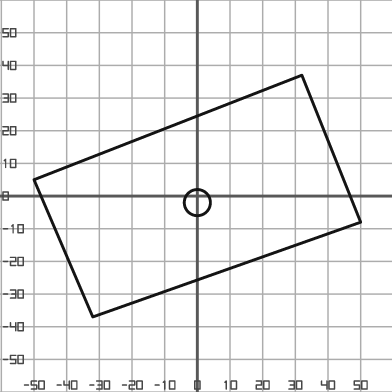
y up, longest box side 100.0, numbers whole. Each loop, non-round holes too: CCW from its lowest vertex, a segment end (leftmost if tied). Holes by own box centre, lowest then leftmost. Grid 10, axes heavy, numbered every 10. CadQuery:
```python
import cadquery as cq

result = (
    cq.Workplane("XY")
    .moveTo(-32.0, -37.0)
    .lineTo(50.0, -8.0)
    .lineTo(32.0, 37.0)
    .lineTo(-50.0, 5.0)
    .close()
    .moveTo(0.0, -2.0)
    .circle(4.0)
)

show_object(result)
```